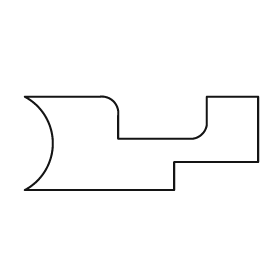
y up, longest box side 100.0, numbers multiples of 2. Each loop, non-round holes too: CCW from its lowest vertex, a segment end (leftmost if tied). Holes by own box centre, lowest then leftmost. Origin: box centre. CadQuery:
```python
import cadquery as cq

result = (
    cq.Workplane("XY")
    .moveTo(-50.0, -20.0)
    .lineTo(14.0, -20.0)
    .lineTo(14.0, -8.0)
    .lineTo(50.0, -8.0)
    .lineTo(50.0, 20.0)
    .lineTo(28.0, 20.0)
    .lineTo(28.0, 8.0)
    .threePointArc((26.0, 4.0), (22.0, 2.0))
    .lineTo(-10.0, 2.0)
    .lineTo(-10.0, 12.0)
    .threePointArc((-12.0, 18.0), (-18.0, 20.0))
    .lineTo(-50.0, 20.0)
    .threePointArc((-38.0, 0.0), (-50.0, -20.0))
    .close()
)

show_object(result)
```